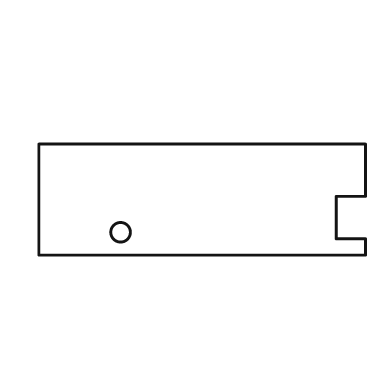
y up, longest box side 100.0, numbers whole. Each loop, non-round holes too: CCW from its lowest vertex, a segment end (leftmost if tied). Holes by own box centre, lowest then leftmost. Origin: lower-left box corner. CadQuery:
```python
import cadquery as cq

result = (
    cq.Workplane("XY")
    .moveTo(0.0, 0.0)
    .lineTo(100.0, 0.0)
    .lineTo(100.0, 5.0)
    .lineTo(91.0, 5.0)
    .lineTo(91.0, 18.0)
    .lineTo(100.0, 18.0)
    .lineTo(100.0, 34.0)
    .lineTo(0.0, 34.0)
    .close()
    .moveTo(25.0, 7.0)
    .circle(3.0)
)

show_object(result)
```